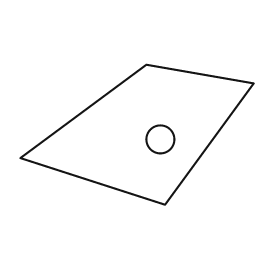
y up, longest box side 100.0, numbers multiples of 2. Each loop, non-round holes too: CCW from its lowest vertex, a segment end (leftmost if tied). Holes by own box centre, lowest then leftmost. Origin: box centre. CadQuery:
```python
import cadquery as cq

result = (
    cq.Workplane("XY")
    .moveTo(12.0, -30.0)
    .lineTo(50.0, 22.0)
    .lineTo(4.0, 30.0)
    .lineTo(-50.0, -10.0)
    .close()
    .moveTo(10.0, -2.0)
    .circle(6.0)
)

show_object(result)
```